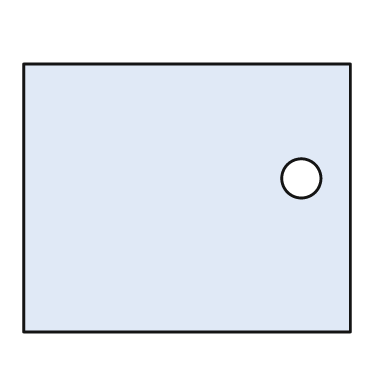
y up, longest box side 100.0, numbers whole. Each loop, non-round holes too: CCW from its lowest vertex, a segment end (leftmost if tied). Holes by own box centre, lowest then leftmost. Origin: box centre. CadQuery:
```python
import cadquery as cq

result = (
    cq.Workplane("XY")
    .moveTo(-50.0, -41.0)
    .lineTo(50.0, -41.0)
    .lineTo(50.0, 41.0)
    .lineTo(-50.0, 41.0)
    .close()
    .moveTo(35.0, 6.0)
    .circle(6.0)
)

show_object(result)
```